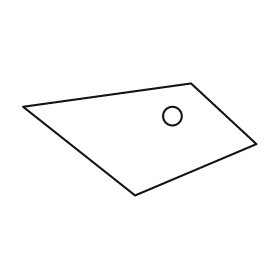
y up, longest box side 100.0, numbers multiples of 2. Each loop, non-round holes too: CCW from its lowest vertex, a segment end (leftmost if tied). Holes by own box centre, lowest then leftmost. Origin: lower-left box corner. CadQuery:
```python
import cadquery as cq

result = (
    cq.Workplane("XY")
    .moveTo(48.0, 0.0)
    .lineTo(100.0, 22.0)
    .lineTo(72.0, 48.0)
    .lineTo(0.0, 38.0)
    .close()
    .moveTo(64.0, 34.0)
    .circle(4.0)
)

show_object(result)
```